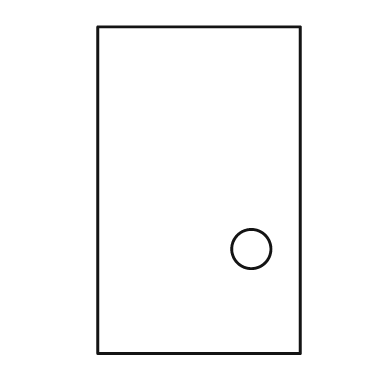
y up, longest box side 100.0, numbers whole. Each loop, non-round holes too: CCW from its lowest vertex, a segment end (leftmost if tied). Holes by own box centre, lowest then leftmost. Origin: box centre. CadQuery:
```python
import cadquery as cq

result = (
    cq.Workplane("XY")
    .moveTo(-31.0, -50.0)
    .lineTo(31.0, -50.0)
    .lineTo(31.0, 50.0)
    .lineTo(-31.0, 50.0)
    .close()
    .moveTo(16.0, -18.0)
    .circle(6.0)
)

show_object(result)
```